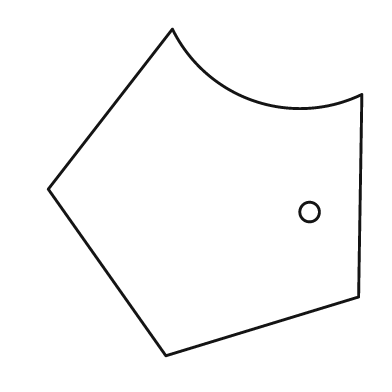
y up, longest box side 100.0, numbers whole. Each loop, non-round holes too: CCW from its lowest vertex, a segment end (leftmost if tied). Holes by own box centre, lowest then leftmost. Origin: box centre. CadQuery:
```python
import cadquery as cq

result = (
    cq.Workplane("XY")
    .moveTo(-12.0, -50.0)
    .lineTo(47.0, -32.0)
    .lineTo(48.0, 30.0)
    .threePointArc((15.0, 28.0), (-10.0, 50.0))
    .lineTo(-48.0, 1.0)
    .close()
    .moveTo(32.0, -6.0)
    .circle(3.0)
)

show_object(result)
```